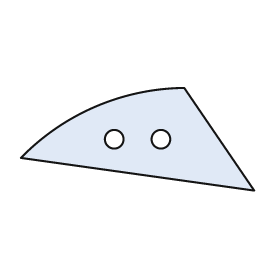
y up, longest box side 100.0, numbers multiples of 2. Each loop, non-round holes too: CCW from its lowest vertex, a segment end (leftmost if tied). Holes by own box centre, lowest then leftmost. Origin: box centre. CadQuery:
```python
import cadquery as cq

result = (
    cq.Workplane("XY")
    .moveTo(50.0, -22.0)
    .lineTo(20.0, 22.0)
    .threePointArc((-18.0, 14.0), (-50.0, -8.0))
    .close()
    .moveTo(-10.0, 0.0)
    .circle(4.0)
    .moveTo(10.0, 0.0)
    .circle(4.0)
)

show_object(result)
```